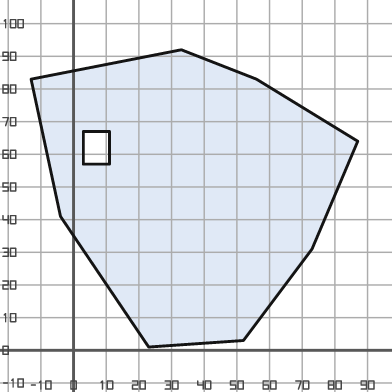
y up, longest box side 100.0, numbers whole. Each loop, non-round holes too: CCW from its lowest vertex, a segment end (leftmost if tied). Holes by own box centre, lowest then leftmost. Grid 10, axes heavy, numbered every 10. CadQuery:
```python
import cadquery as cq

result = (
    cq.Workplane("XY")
    .moveTo(23.0, 1.0)
    .lineTo(52.0, 3.0)
    .lineTo(73.0, 31.0)
    .lineTo(87.0, 64.0)
    .lineTo(56.0, 83.0)
    .lineTo(33.0, 92.0)
    .lineTo(-13.0, 83.0)
    .lineTo(-4.0, 41.0)
    .close()
    .moveTo(3.0, 57.0)
    .lineTo(11.0, 57.0)
    .lineTo(11.0, 67.0)
    .lineTo(3.0, 67.0)
    .close()
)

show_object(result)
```